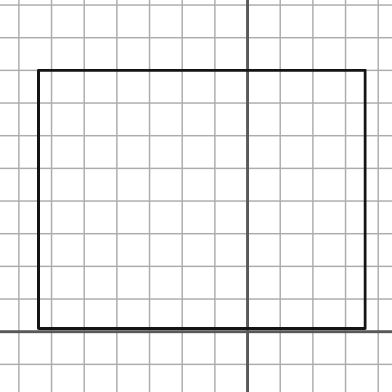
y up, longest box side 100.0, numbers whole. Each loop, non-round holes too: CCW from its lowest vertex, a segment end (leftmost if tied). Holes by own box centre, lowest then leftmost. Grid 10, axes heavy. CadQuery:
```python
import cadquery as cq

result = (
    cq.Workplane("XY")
    .moveTo(-64.0, 1.0)
    .lineTo(36.0, 1.0)
    .lineTo(36.0, 80.0)
    .lineTo(-64.0, 80.0)
    .close()
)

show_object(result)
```